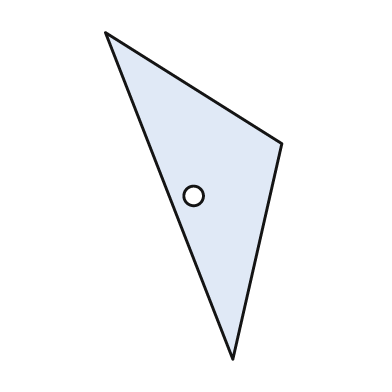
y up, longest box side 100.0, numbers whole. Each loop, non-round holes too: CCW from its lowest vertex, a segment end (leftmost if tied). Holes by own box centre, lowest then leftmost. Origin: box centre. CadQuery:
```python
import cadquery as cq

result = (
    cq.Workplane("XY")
    .moveTo(12.0, -50.0)
    .lineTo(27.0, 16.0)
    .lineTo(-27.0, 50.0)
    .close()
    .moveTo(0.0, 0.0)
    .circle(3.0)
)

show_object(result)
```